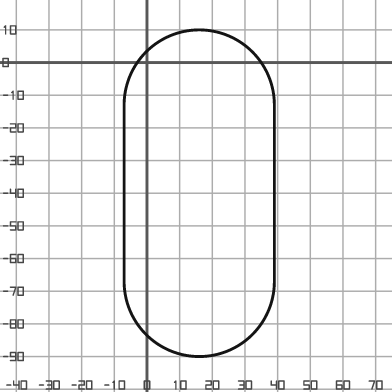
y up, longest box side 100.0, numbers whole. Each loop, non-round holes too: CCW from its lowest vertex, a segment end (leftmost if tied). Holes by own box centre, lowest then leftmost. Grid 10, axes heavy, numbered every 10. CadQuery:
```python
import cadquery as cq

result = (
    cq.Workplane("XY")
    .moveTo(-7.0, -67.0)
    .threePointArc((16.0, -90.0), (39.0, -67.0))
    .lineTo(39.0, -13.0)
    .threePointArc((16.0, 10.0), (-7.0, -13.0))
    .close()
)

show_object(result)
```